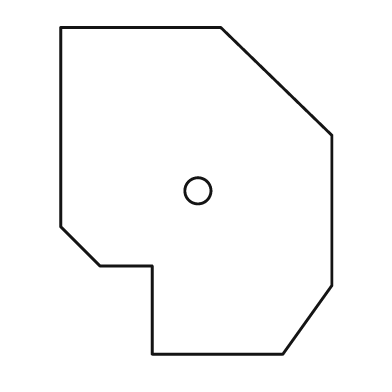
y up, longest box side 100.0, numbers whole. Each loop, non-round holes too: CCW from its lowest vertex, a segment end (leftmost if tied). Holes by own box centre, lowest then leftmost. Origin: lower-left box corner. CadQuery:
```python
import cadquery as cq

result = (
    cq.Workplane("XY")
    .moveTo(28.0, 0.0)
    .lineTo(68.0, 0.0)
    .lineTo(83.0, 21.0)
    .lineTo(83.0, 67.0)
    .lineTo(49.0, 100.0)
    .lineTo(0.0, 100.0)
    .lineTo(0.0, 39.0)
    .lineTo(12.0, 27.0)
    .lineTo(28.0, 27.0)
    .close()
    .moveTo(42.0, 50.0)
    .circle(4.0)
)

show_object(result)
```